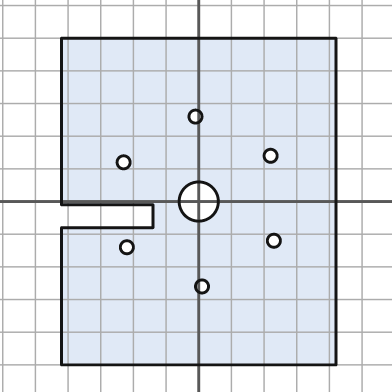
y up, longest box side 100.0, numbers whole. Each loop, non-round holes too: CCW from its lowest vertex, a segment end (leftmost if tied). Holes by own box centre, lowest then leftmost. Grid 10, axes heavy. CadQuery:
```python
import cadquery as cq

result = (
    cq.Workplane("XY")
    .moveTo(-42.0, -50.0)
    .lineTo(42.0, -50.0)
    .lineTo(42.0, 50.0)
    .lineTo(-42.0, 50.0)
    .lineTo(-42.0, -1.0)
    .lineTo(-14.0, -1.0)
    .lineTo(-14.0, -8.0)
    .lineTo(-42.0, -8.0)
    .close()
    .moveTo(1.0, -26.0)
    .circle(2.0)
    .moveTo(-22.0, -14.0)
    .circle(2.0)
    .moveTo(23.0, -12.0)
    .circle(2.0)
    .moveTo(0.0, 0.0)
    .circle(6.0)
    .moveTo(-23.0, 12.0)
    .circle(2.0)
    .moveTo(22.0, 14.0)
    .circle(2.0)
    .moveTo(-1.0, 26.0)
    .circle(2.0)
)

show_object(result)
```